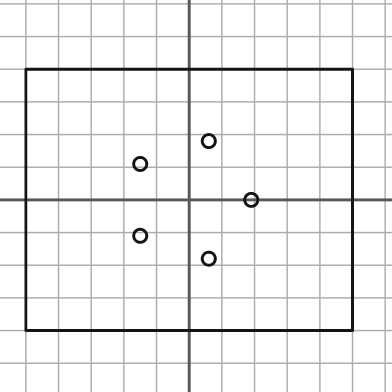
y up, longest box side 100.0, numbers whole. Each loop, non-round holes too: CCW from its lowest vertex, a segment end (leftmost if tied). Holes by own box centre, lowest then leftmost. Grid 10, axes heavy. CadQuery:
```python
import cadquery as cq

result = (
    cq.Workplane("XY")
    .moveTo(-50.0, -40.0)
    .lineTo(50.0, -40.0)
    .lineTo(50.0, 40.0)
    .lineTo(-50.0, 40.0)
    .close()
    .moveTo(6.0, -18.0)
    .circle(2.0)
    .moveTo(-15.0, -11.0)
    .circle(2.0)
    .moveTo(19.0, 0.0)
    .circle(2.0)
    .moveTo(-15.0, 11.0)
    .circle(2.0)
    .moveTo(6.0, 18.0)
    .circle(2.0)
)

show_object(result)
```